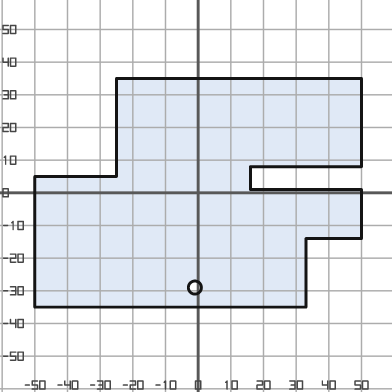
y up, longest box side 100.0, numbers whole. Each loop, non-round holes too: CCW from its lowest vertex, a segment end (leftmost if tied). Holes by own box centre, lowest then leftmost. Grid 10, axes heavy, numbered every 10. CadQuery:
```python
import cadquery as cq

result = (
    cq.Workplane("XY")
    .moveTo(-50.0, -35.0)
    .lineTo(33.0, -35.0)
    .lineTo(33.0, -14.0)
    .lineTo(50.0, -14.0)
    .lineTo(50.0, 1.0)
    .lineTo(16.0, 1.0)
    .lineTo(16.0, 8.0)
    .lineTo(50.0, 8.0)
    .lineTo(50.0, 35.0)
    .lineTo(-25.0, 35.0)
    .lineTo(-25.0, 5.0)
    .lineTo(-50.0, 5.0)
    .close()
    .moveTo(-1.0, -29.0)
    .circle(2.0)
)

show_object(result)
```